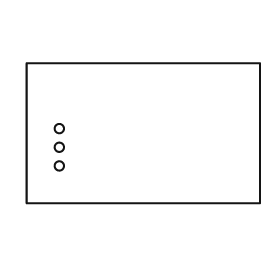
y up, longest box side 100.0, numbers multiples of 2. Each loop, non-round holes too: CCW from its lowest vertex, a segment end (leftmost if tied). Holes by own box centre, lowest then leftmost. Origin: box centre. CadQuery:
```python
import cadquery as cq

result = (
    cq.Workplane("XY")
    .moveTo(-50.0, -30.0)
    .lineTo(50.0, -30.0)
    .lineTo(50.0, 30.0)
    .lineTo(-50.0, 30.0)
    .close()
    .moveTo(-36.0, -14.0)
    .circle(2.0)
    .moveTo(-36.0, -6.0)
    .circle(2.0)
    .moveTo(-36.0, 2.0)
    .circle(2.0)
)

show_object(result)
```